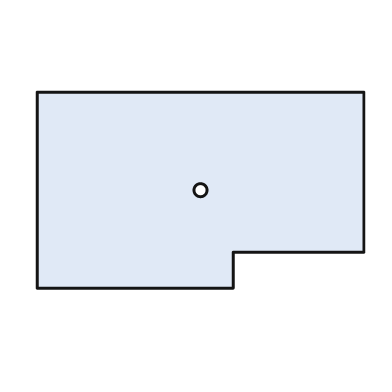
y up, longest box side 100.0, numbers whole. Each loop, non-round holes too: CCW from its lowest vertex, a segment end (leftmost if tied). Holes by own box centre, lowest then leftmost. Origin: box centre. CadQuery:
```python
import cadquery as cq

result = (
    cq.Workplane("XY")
    .moveTo(-50.0, -30.0)
    .lineTo(10.0, -30.0)
    .lineTo(10.0, -19.0)
    .lineTo(50.0, -19.0)
    .lineTo(50.0, 30.0)
    .lineTo(-50.0, 30.0)
    .close()
    .moveTo(0.0, 0.0)
    .circle(2.0)
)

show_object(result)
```